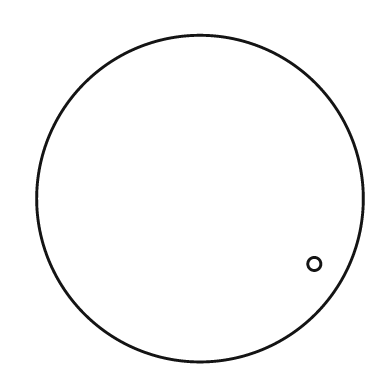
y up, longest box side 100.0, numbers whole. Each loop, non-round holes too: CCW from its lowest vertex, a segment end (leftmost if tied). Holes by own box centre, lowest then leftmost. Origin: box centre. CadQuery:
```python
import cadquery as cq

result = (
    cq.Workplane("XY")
    .moveTo(0.0, 0.0)
    .circle(50.0)
    .moveTo(35.0, -20.0)
    .circle(2.0)
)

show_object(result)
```